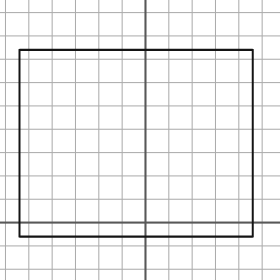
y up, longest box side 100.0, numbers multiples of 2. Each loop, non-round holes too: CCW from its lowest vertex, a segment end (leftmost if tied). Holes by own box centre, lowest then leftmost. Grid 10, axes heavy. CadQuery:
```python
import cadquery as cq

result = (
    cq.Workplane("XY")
    .moveTo(-54.0, -6.0)
    .lineTo(46.0, -6.0)
    .lineTo(46.0, 74.0)
    .lineTo(-54.0, 74.0)
    .close()
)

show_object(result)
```